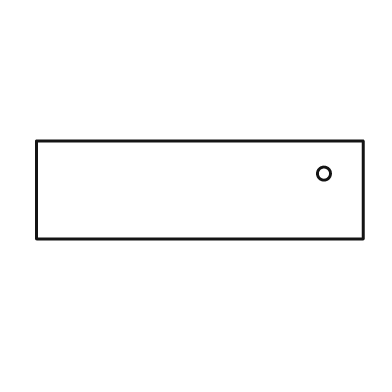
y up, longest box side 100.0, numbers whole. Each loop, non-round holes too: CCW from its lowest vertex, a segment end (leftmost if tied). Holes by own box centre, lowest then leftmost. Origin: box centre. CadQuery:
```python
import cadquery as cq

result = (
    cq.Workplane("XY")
    .moveTo(-50.0, -15.0)
    .lineTo(50.0, -15.0)
    .lineTo(50.0, 15.0)
    .lineTo(-50.0, 15.0)
    .close()
    .moveTo(38.0, 5.0)
    .circle(2.0)
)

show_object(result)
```